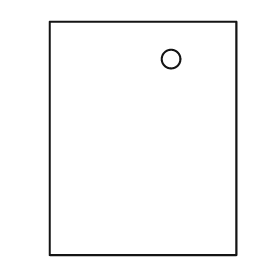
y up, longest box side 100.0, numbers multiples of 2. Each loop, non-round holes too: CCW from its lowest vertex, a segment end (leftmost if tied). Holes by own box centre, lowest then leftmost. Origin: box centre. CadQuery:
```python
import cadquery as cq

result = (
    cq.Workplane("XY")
    .moveTo(-40.0, -50.0)
    .lineTo(40.0, -50.0)
    .lineTo(40.0, 50.0)
    .lineTo(-40.0, 50.0)
    .close()
    .moveTo(12.0, 34.0)
    .circle(4.0)
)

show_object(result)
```